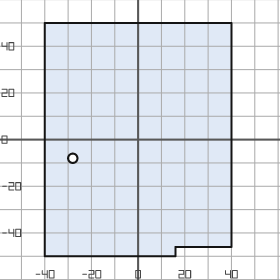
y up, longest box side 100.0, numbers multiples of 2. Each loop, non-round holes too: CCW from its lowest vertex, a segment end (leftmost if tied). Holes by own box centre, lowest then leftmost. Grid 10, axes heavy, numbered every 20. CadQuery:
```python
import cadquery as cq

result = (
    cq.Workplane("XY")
    .moveTo(-40.0, -50.0)
    .lineTo(16.0, -50.0)
    .lineTo(16.0, -46.0)
    .lineTo(40.0, -46.0)
    .lineTo(40.0, 50.0)
    .lineTo(-40.0, 50.0)
    .close()
    .moveTo(-28.0, -8.0)
    .circle(2.0)
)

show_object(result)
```